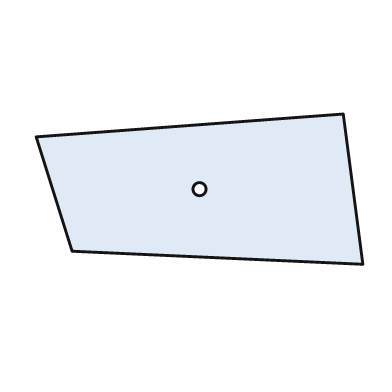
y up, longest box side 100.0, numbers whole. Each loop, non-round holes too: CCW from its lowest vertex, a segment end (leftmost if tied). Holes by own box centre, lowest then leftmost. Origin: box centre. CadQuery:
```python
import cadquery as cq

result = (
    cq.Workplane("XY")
    .moveTo(50.0, -23.0)
    .lineTo(44.0, 23.0)
    .lineTo(-50.0, 16.0)
    .lineTo(-39.0, -19.0)
    .close()
    .moveTo(0.0, 0.0)
    .circle(2.0)
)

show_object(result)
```